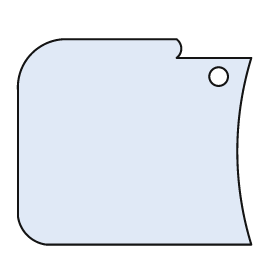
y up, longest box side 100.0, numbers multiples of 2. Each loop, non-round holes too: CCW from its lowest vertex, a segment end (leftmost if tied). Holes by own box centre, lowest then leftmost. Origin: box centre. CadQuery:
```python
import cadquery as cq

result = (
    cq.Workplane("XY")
    .moveTo(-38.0, -44.0)
    .lineTo(50.0, -44.0)
    .threePointArc((44.0, -4.0), (50.0, 36.0))
    .lineTo(18.0, 36.0)
    .threePointArc((20.0, 40.0), (18.0, 44.0))
    .lineTo(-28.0, 44.0)
    .threePointArc((-44.0, 38.0), (-50.0, 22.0))
    .lineTo(-50.0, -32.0)
    .threePointArc((-46.0, -40.0), (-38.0, -44.0))
    .close()
    .moveTo(36.0, 28.0)
    .circle(4.0)
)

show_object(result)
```